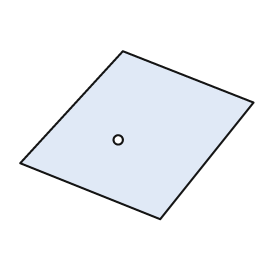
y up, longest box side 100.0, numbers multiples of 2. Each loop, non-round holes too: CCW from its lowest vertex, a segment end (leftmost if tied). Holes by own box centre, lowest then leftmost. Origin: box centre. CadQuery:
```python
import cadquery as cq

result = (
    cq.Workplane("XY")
    .moveTo(10.0, -36.0)
    .lineTo(50.0, 14.0)
    .lineTo(-6.0, 36.0)
    .lineTo(-50.0, -12.0)
    .close()
    .moveTo(-8.0, -2.0)
    .circle(2.0)
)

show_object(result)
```